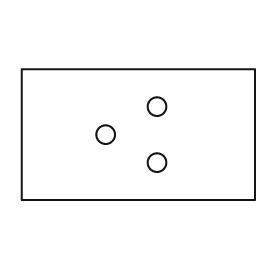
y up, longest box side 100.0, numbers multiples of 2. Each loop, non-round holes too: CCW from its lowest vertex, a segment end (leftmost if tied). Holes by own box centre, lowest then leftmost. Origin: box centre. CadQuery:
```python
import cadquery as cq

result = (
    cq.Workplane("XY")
    .moveTo(-50.0, -28.0)
    .lineTo(50.0, -28.0)
    .lineTo(50.0, 28.0)
    .lineTo(-50.0, 28.0)
    .close()
    .moveTo(8.0, -12.0)
    .circle(4.0)
    .moveTo(-14.0, 0.0)
    .circle(4.0)
    .moveTo(8.0, 12.0)
    .circle(4.0)
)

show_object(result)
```